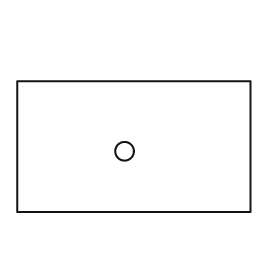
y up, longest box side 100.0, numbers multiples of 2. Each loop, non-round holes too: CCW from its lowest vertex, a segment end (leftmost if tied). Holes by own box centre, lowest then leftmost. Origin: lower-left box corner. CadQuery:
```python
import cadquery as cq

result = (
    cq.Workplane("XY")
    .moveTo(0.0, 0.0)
    .lineTo(100.0, 0.0)
    .lineTo(100.0, 56.0)
    .lineTo(0.0, 56.0)
    .close()
    .moveTo(46.0, 26.0)
    .circle(4.0)
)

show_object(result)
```